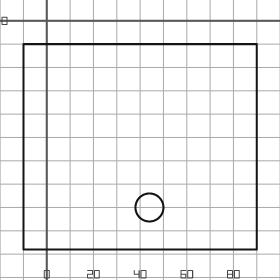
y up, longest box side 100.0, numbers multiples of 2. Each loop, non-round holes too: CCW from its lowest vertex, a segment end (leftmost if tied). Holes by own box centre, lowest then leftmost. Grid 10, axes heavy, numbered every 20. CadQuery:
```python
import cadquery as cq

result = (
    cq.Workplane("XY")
    .moveTo(-10.0, -98.0)
    .lineTo(90.0, -98.0)
    .lineTo(90.0, -10.0)
    .lineTo(-10.0, -10.0)
    .close()
    .moveTo(44.0, -80.0)
    .circle(6.0)
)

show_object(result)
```